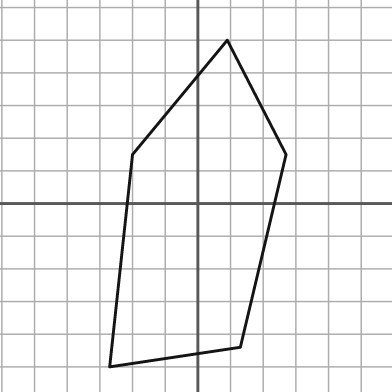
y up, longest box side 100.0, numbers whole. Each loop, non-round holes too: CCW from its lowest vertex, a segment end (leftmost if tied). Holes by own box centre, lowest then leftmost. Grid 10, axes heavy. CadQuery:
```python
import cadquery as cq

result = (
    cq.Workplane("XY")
    .moveTo(-27.0, -50.0)
    .lineTo(13.0, -44.0)
    .lineTo(27.0, 15.0)
    .lineTo(9.0, 50.0)
    .lineTo(-20.0, 15.0)
    .close()
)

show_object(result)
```